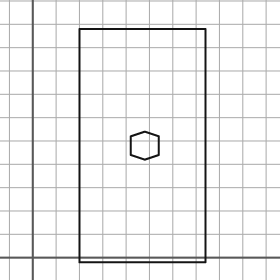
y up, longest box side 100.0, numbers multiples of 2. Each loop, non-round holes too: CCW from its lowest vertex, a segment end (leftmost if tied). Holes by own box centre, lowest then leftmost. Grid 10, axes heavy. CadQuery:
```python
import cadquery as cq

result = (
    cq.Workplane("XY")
    .moveTo(20.0, -2.0)
    .lineTo(74.0, -2.0)
    .lineTo(74.0, 98.0)
    .lineTo(20.0, 98.0)
    .close()
    .moveTo(48.0, 42.0)
    .lineTo(54.0, 44.0)
    .lineTo(54.0, 52.0)
    .lineTo(48.0, 54.0)
    .lineTo(42.0, 52.0)
    .lineTo(42.0, 44.0)
    .close()
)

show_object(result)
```